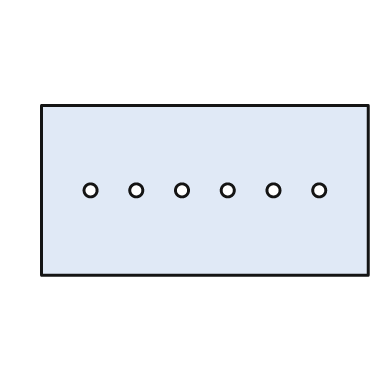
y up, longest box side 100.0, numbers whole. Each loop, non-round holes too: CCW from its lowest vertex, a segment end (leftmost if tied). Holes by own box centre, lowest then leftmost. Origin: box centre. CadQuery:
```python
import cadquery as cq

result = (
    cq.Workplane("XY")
    .moveTo(-50.0, -26.0)
    .lineTo(50.0, -26.0)
    .lineTo(50.0, 26.0)
    .lineTo(-50.0, 26.0)
    .close()
    .moveTo(-35.0, 0.0)
    .circle(2.0)
    .moveTo(-21.0, 0.0)
    .circle(2.0)
    .moveTo(-7.0, 0.0)
    .circle(2.0)
    .moveTo(7.0, 0.0)
    .circle(2.0)
    .moveTo(21.0, 0.0)
    .circle(2.0)
    .moveTo(35.0, 0.0)
    .circle(2.0)
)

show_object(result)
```